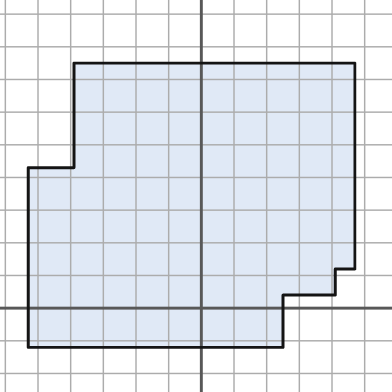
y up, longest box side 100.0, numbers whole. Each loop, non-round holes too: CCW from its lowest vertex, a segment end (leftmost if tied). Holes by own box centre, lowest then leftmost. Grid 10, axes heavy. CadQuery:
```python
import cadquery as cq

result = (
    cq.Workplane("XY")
    .moveTo(-53.0, -12.0)
    .lineTo(25.0, -12.0)
    .lineTo(25.0, 4.0)
    .lineTo(41.0, 4.0)
    .lineTo(41.0, 12.0)
    .lineTo(47.0, 12.0)
    .lineTo(47.0, 75.0)
    .lineTo(-39.0, 75.0)
    .lineTo(-39.0, 43.0)
    .lineTo(-53.0, 43.0)
    .close()
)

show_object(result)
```